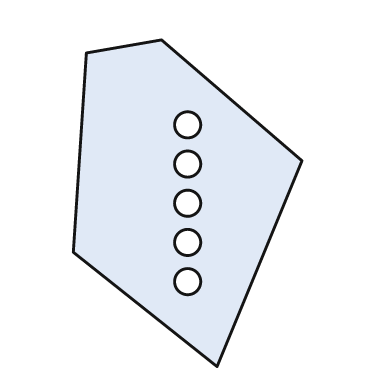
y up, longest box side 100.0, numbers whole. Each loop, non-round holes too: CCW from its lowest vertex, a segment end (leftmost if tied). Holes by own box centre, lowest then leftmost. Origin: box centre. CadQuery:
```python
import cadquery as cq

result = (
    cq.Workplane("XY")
    .moveTo(9.0, -50.0)
    .lineTo(35.0, 13.0)
    .lineTo(-8.0, 50.0)
    .lineTo(-31.0, 46.0)
    .lineTo(-35.0, -15.0)
    .close()
    .moveTo(0.0, -24.0)
    .circle(4.0)
    .moveTo(0.0, -12.0)
    .circle(4.0)
    .moveTo(0.0, 0.0)
    .circle(4.0)
    .moveTo(0.0, 12.0)
    .circle(4.0)
    .moveTo(0.0, 24.0)
    .circle(4.0)
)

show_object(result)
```